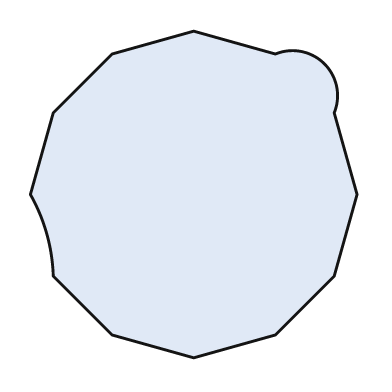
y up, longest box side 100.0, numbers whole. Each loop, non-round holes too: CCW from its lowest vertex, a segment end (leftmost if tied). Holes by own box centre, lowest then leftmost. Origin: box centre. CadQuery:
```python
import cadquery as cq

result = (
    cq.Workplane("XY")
    .moveTo(0.0, -50.0)
    .lineTo(25.0, -43.0)
    .lineTo(43.0, -25.0)
    .lineTo(50.0, 0.0)
    .lineTo(43.0, 25.0)
    .threePointArc((40.0, 40.0), (25.0, 43.0))
    .lineTo(0.0, 50.0)
    .lineTo(-25.0, 43.0)
    .lineTo(-43.0, 25.0)
    .lineTo(-50.0, 0.0)
    .threePointArc((-45.0, -12.0), (-43.0, -25.0))
    .lineTo(-25.0, -43.0)
    .close()
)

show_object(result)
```